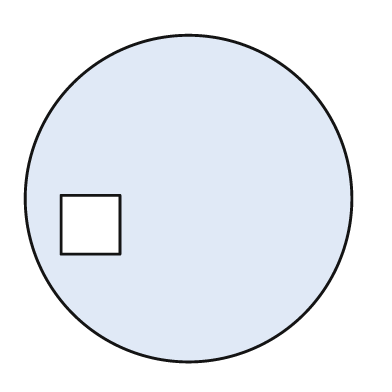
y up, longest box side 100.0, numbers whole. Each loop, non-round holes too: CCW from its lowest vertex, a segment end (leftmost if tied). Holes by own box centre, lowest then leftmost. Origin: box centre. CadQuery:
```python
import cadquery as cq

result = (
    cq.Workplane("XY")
    .moveTo(0.0, 0.0)
    .circle(50.0)
    .moveTo(-39.0, -17.0)
    .lineTo(-21.0, -17.0)
    .lineTo(-21.0, 1.0)
    .lineTo(-39.0, 1.0)
    .close()
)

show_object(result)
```